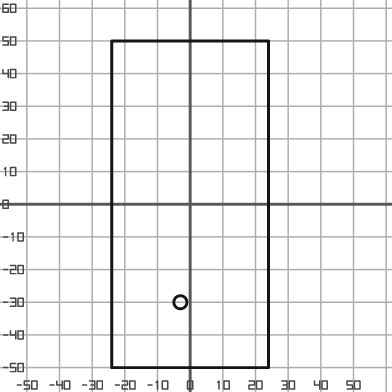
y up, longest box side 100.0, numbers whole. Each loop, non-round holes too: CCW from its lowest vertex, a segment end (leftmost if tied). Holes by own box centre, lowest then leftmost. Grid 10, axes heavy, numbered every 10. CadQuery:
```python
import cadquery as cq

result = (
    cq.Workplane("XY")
    .moveTo(-24.0, -50.0)
    .lineTo(24.0, -50.0)
    .lineTo(24.0, 50.0)
    .lineTo(-24.0, 50.0)
    .close()
    .moveTo(-3.0, -30.0)
    .circle(2.0)
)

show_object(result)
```